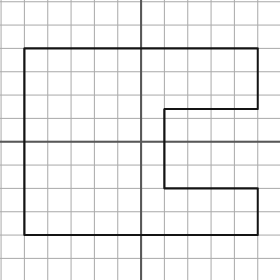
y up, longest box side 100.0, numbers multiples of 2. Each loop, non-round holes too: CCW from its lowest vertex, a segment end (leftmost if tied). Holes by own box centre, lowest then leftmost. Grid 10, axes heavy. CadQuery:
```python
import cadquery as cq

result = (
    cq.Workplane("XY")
    .moveTo(-50.0, -40.0)
    .lineTo(50.0, -40.0)
    .lineTo(50.0, -20.0)
    .lineTo(10.0, -20.0)
    .lineTo(10.0, 14.0)
    .lineTo(50.0, 14.0)
    .lineTo(50.0, 40.0)
    .lineTo(-50.0, 40.0)
    .close()
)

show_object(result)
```